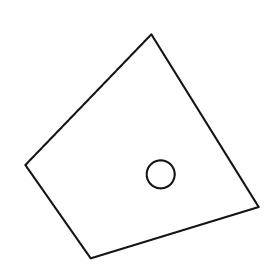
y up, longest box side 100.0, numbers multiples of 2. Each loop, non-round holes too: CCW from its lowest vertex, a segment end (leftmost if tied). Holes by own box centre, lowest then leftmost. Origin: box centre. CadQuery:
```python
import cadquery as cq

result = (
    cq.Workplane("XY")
    .moveTo(-22.0, -48.0)
    .lineTo(50.0, -26.0)
    .lineTo(4.0, 48.0)
    .lineTo(-50.0, -8.0)
    .close()
    .moveTo(8.0, -12.0)
    .circle(6.0)
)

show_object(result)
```